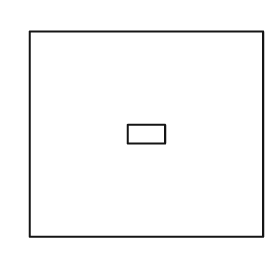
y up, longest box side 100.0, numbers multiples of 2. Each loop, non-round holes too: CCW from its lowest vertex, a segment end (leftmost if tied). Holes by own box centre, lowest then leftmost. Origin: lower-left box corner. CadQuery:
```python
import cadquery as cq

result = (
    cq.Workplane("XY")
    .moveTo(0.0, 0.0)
    .lineTo(100.0, 0.0)
    .lineTo(100.0, 88.0)
    .lineTo(0.0, 88.0)
    .close()
    .moveTo(42.0, 40.0)
    .lineTo(58.0, 40.0)
    .lineTo(58.0, 48.0)
    .lineTo(42.0, 48.0)
    .close()
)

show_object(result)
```